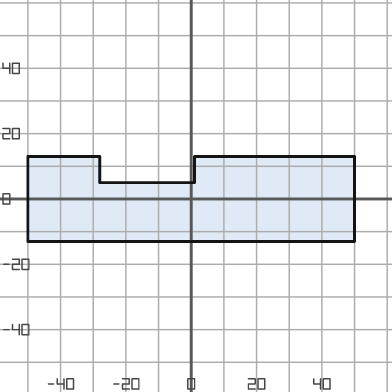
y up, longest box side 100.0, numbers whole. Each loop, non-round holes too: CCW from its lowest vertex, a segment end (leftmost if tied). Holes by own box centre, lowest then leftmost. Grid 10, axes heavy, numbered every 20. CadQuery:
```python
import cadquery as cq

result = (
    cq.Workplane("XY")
    .moveTo(-50.0, -13.0)
    .lineTo(50.0, -13.0)
    .lineTo(50.0, 13.0)
    .lineTo(1.0, 13.0)
    .lineTo(1.0, 5.0)
    .lineTo(-28.0, 5.0)
    .lineTo(-28.0, 13.0)
    .lineTo(-50.0, 13.0)
    .close()
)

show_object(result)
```